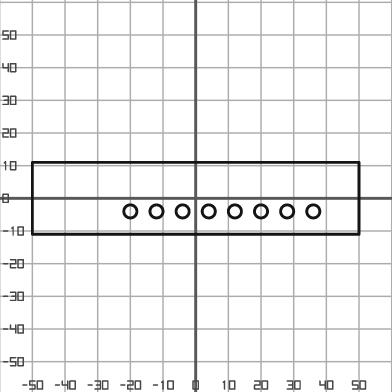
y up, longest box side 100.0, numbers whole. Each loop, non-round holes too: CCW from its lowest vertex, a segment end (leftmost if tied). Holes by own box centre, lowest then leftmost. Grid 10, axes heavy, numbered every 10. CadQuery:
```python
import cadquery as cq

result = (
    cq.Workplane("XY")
    .moveTo(-50.0, -11.0)
    .lineTo(50.0, -11.0)
    .lineTo(50.0, 11.0)
    .lineTo(-50.0, 11.0)
    .close()
    .moveTo(-20.0, -4.0)
    .circle(2.0)
    .moveTo(-12.0, -4.0)
    .circle(2.0)
    .moveTo(-4.0, -4.0)
    .circle(2.0)
    .moveTo(4.0, -4.0)
    .circle(2.0)
    .moveTo(12.0, -4.0)
    .circle(2.0)
    .moveTo(20.0, -4.0)
    .circle(2.0)
    .moveTo(28.0, -4.0)
    .circle(2.0)
    .moveTo(36.0, -4.0)
    .circle(2.0)
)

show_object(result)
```